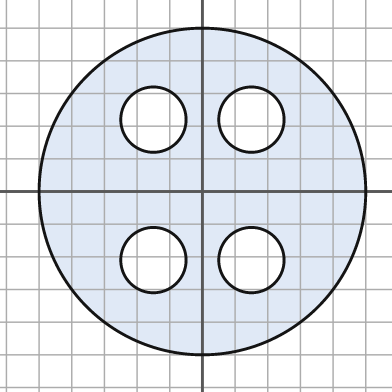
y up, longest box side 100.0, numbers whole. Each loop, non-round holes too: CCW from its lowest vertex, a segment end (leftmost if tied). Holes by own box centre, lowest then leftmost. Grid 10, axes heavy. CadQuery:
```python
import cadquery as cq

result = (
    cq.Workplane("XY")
    .moveTo(0.0, 0.0)
    .circle(50.0)
    .moveTo(-15.0, -21.0)
    .circle(10.0)
    .moveTo(15.0, -21.0)
    .circle(10.0)
    .moveTo(-15.0, 22.0)
    .circle(10.0)
    .moveTo(15.0, 22.0)
    .circle(10.0)
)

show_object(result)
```